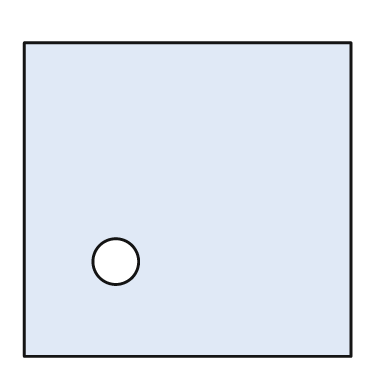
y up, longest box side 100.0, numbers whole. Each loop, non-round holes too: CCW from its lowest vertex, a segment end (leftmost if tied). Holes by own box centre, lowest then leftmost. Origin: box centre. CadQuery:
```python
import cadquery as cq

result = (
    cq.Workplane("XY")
    .moveTo(-50.0, -48.0)
    .lineTo(50.0, -48.0)
    .lineTo(50.0, 48.0)
    .lineTo(-50.0, 48.0)
    .close()
    .moveTo(-22.0, -19.0)
    .circle(7.0)
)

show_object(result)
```